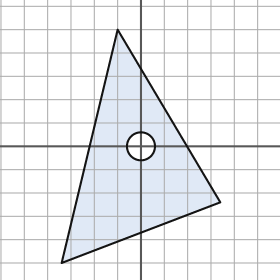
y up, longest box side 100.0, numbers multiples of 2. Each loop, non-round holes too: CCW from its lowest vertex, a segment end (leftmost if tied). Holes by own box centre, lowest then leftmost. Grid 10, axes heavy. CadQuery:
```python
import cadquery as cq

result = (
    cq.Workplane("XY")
    .moveTo(-34.0, -50.0)
    .lineTo(34.0, -24.0)
    .lineTo(-10.0, 50.0)
    .close()
    .moveTo(0.0, 0.0)
    .circle(6.0)
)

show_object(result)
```